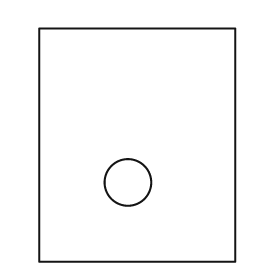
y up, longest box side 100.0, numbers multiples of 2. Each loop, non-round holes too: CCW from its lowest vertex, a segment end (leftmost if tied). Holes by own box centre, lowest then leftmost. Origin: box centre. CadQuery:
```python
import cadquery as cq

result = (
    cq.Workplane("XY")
    .moveTo(-42.0, -50.0)
    .lineTo(42.0, -50.0)
    .lineTo(42.0, 50.0)
    .lineTo(-42.0, 50.0)
    .close()
    .moveTo(-4.0, -16.0)
    .circle(10.0)
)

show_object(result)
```